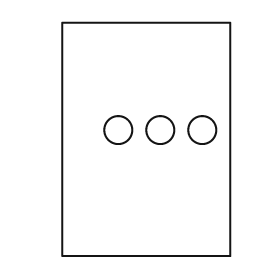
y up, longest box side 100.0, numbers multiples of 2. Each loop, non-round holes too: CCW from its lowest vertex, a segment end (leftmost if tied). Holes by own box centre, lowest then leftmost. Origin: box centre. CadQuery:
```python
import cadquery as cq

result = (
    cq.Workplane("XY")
    .moveTo(-36.0, -50.0)
    .lineTo(36.0, -50.0)
    .lineTo(36.0, 50.0)
    .lineTo(-36.0, 50.0)
    .close()
    .moveTo(-12.0, 4.0)
    .circle(6.0)
    .moveTo(6.0, 4.0)
    .circle(6.0)
    .moveTo(24.0, 4.0)
    .circle(6.0)
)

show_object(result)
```